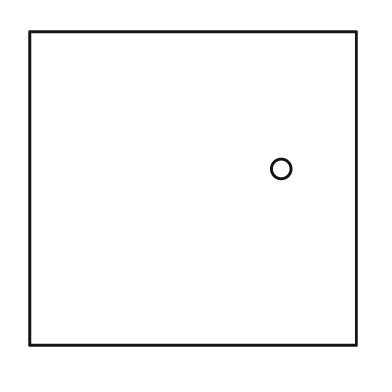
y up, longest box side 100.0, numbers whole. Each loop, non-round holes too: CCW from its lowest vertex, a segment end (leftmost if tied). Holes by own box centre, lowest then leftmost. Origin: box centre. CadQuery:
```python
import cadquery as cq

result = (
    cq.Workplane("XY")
    .moveTo(-50.0, -48.0)
    .lineTo(50.0, -48.0)
    .lineTo(50.0, 48.0)
    .lineTo(-50.0, 48.0)
    .close()
    .moveTo(27.0, 6.0)
    .circle(3.0)
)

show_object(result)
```